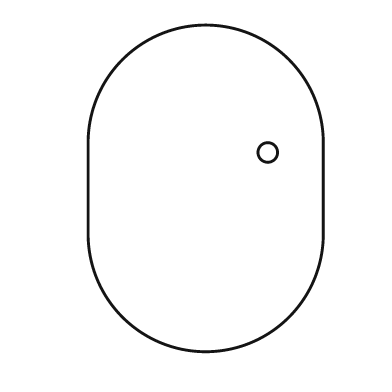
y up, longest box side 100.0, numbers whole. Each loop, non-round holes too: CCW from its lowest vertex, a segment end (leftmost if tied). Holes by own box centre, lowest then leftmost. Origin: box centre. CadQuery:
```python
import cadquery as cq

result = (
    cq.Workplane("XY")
    .moveTo(-36.0, -14.0)
    .threePointArc((0.0, -50.0), (36.0, -14.0))
    .lineTo(36.0, 14.0)
    .threePointArc((0.0, 50.0), (-36.0, 14.0))
    .close()
    .moveTo(19.0, 11.0)
    .circle(3.0)
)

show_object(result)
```